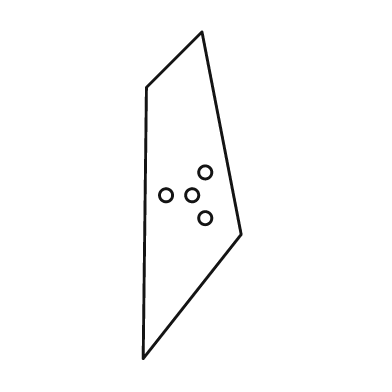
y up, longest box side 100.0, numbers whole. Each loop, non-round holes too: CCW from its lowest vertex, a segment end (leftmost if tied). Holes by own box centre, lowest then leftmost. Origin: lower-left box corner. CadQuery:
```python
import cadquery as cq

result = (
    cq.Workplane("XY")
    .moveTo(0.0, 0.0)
    .lineTo(30.0, 38.0)
    .lineTo(18.0, 100.0)
    .lineTo(1.0, 83.0)
    .close()
    .moveTo(19.0, 43.0)
    .circle(2.0)
    .moveTo(7.0, 50.0)
    .circle(2.0)
    .moveTo(15.0, 50.0)
    .circle(2.0)
    .moveTo(19.0, 57.0)
    .circle(2.0)
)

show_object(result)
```